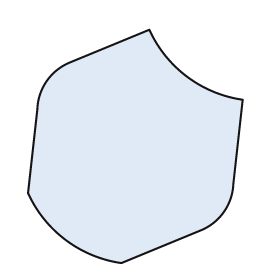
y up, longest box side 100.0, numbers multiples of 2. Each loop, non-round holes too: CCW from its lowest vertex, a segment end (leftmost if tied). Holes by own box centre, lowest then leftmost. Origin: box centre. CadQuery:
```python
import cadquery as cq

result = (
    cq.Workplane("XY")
    .moveTo(-6.0, -50.0)
    .lineTo(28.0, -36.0)
    .threePointArc((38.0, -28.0), (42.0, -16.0))
    .lineTo(46.0, 20.0)
    .threePointArc((22.0, 30.0), (6.0, 50.0))
    .lineTo(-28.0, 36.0)
    .threePointArc((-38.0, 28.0), (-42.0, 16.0))
    .lineTo(-46.0, -20.0)
    .threePointArc((-30.0, -40.0), (-6.0, -50.0))
    .close()
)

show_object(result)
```